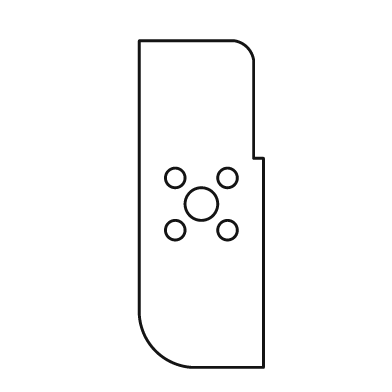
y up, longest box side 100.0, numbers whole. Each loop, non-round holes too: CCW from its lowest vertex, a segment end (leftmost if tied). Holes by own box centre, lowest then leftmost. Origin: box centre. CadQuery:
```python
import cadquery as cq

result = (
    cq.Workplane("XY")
    .moveTo(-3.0, -50.0)
    .lineTo(19.0, -50.0)
    .lineTo(19.0, 14.0)
    .lineTo(16.0, 14.0)
    .lineTo(16.0, 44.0)
    .threePointArc((14.0, 48.0), (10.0, 50.0))
    .lineTo(-19.0, 50.0)
    .lineTo(-19.0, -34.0)
    .threePointArc((-14.0, -45.0), (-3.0, -50.0))
    .close()
    .moveTo(-8.0, -8.0)
    .circle(3.0)
    .moveTo(8.0, -8.0)
    .circle(3.0)
    .moveTo(0.0, 0.0)
    .circle(5.0)
    .moveTo(-8.0, 8.0)
    .circle(3.0)
    .moveTo(8.0, 8.0)
    .circle(3.0)
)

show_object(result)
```